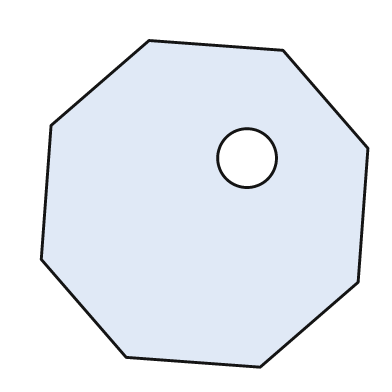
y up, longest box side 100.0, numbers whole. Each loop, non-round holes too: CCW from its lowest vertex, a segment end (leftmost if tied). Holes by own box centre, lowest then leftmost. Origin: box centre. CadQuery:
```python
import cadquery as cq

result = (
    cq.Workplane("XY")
    .moveTo(17.0, -50.0)
    .lineTo(47.0, -24.0)
    .lineTo(50.0, 17.0)
    .lineTo(24.0, 47.0)
    .lineTo(-17.0, 50.0)
    .lineTo(-47.0, 24.0)
    .lineTo(-50.0, -17.0)
    .lineTo(-24.0, -47.0)
    .close()
    .moveTo(13.0, 14.0)
    .circle(9.0)
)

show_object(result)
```